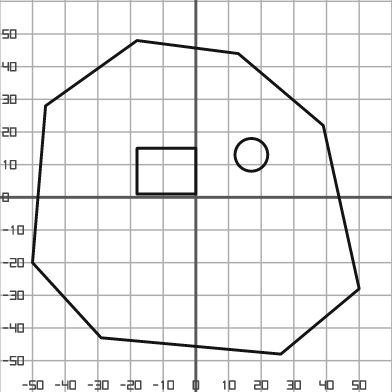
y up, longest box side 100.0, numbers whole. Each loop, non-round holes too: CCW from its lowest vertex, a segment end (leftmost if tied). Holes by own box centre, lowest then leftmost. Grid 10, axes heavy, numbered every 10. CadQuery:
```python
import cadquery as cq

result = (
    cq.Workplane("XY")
    .moveTo(26.0, -48.0)
    .lineTo(50.0, -28.0)
    .lineTo(39.0, 22.0)
    .lineTo(13.0, 44.0)
    .lineTo(-18.0, 48.0)
    .lineTo(-46.0, 28.0)
    .lineTo(-50.0, -20.0)
    .lineTo(-29.0, -43.0)
    .close()
    .moveTo(-18.0, 1.0)
    .lineTo(0.0, 1.0)
    .lineTo(0.0, 15.0)
    .lineTo(-18.0, 15.0)
    .close()
    .moveTo(17.0, 13.0)
    .circle(5.0)
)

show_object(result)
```